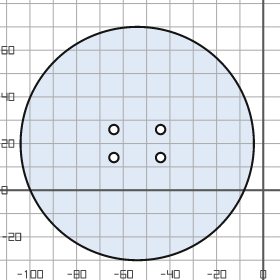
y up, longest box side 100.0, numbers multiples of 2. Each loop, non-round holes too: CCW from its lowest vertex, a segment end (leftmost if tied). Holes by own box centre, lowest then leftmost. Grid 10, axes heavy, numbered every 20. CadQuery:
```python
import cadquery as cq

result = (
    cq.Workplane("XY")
    .moveTo(-54.0, 20.0)
    .circle(50.0)
    .moveTo(-64.0, 14.0)
    .circle(2.0)
    .moveTo(-44.0, 14.0)
    .circle(2.0)
    .moveTo(-64.0, 26.0)
    .circle(2.0)
    .moveTo(-44.0, 26.0)
    .circle(2.0)
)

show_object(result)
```